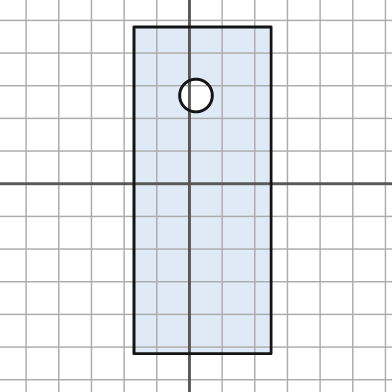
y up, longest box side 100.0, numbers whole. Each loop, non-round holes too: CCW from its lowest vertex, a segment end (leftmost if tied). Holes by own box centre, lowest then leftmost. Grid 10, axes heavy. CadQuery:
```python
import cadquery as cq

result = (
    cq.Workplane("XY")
    .moveTo(-17.0, -52.0)
    .lineTo(25.0, -52.0)
    .lineTo(25.0, 48.0)
    .lineTo(-17.0, 48.0)
    .close()
    .moveTo(2.0, 27.0)
    .circle(5.0)
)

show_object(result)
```